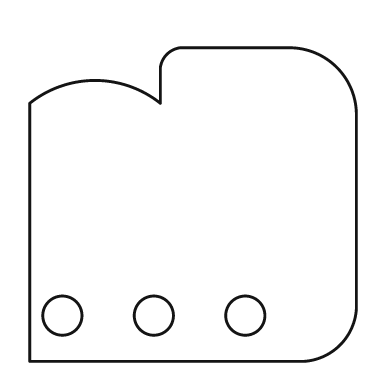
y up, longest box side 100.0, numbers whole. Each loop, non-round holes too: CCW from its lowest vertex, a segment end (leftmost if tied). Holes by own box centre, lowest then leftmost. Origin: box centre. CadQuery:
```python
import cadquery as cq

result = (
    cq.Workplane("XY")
    .moveTo(-50.0, -48.0)
    .lineTo(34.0, -48.0)
    .threePointArc((45.0, -43.0), (50.0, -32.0))
    .lineTo(50.0, 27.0)
    .threePointArc((44.0, 42.0), (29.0, 48.0))
    .lineTo(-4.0, 48.0)
    .threePointArc((-8.0, 46.0), (-10.0, 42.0))
    .lineTo(-10.0, 31.0)
    .threePointArc((-30.0, 38.0), (-50.0, 31.0))
    .close()
    .moveTo(-40.0, -34.0)
    .circle(6.0)
    .moveTo(-12.0, -34.0)
    .circle(6.0)
    .moveTo(16.0, -34.0)
    .circle(6.0)
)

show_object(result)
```